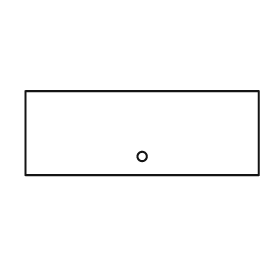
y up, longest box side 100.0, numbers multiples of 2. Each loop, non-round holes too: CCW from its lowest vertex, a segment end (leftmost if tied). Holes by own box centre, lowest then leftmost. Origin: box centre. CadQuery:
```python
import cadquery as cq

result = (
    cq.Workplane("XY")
    .moveTo(-50.0, -18.0)
    .lineTo(50.0, -18.0)
    .lineTo(50.0, 18.0)
    .lineTo(-50.0, 18.0)
    .close()
    .moveTo(0.0, -10.0)
    .circle(2.0)
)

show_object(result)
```